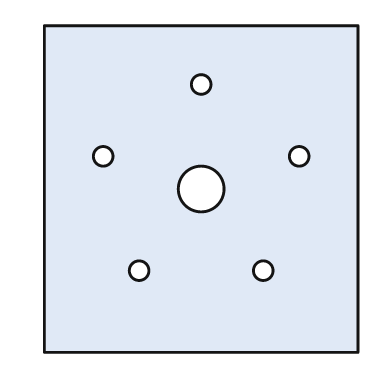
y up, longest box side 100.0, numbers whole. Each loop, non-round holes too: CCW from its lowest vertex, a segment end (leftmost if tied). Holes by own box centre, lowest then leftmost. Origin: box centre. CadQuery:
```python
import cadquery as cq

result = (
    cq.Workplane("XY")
    .moveTo(-48.0, -50.0)
    .lineTo(48.0, -50.0)
    .lineTo(48.0, 50.0)
    .lineTo(-48.0, 50.0)
    .close()
    .moveTo(-19.0, -25.0)
    .circle(3.0)
    .moveTo(19.0, -25.0)
    .circle(3.0)
    .moveTo(0.0, 0.0)
    .circle(7.0)
    .moveTo(-30.0, 10.0)
    .circle(3.0)
    .moveTo(30.0, 10.0)
    .circle(3.0)
    .moveTo(0.0, 32.0)
    .circle(3.0)
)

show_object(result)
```